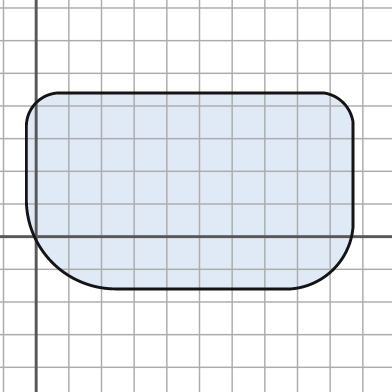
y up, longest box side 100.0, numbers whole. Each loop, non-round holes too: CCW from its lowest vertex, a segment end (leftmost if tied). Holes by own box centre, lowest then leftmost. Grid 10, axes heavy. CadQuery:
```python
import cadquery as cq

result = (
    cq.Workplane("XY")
    .moveTo(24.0, -16.0)
    .lineTo(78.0, -16.0)
    .threePointArc((91.0, -10.0), (97.0, 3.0))
    .lineTo(97.0, 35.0)
    .threePointArc((94.0, 41.0), (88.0, 44.0))
    .lineTo(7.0, 44.0)
    .threePointArc((0.0, 41.0), (-3.0, 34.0))
    .lineTo(-3.0, 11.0)
    .threePointArc((5.0, -8.0), (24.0, -16.0))
    .close()
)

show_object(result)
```